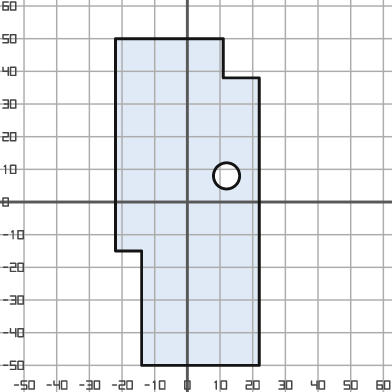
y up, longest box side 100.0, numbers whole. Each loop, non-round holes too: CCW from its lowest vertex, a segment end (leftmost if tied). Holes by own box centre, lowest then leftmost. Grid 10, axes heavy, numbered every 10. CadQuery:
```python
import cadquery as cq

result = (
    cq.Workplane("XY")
    .moveTo(-14.0, -50.0)
    .lineTo(22.0, -50.0)
    .lineTo(22.0, 38.0)
    .lineTo(11.0, 38.0)
    .lineTo(11.0, 50.0)
    .lineTo(-22.0, 50.0)
    .lineTo(-22.0, -15.0)
    .lineTo(-14.0, -15.0)
    .close()
    .moveTo(12.0, 8.0)
    .circle(4.0)
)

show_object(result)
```